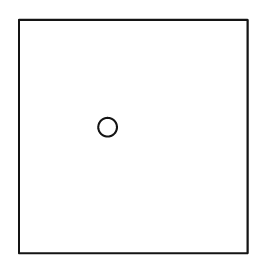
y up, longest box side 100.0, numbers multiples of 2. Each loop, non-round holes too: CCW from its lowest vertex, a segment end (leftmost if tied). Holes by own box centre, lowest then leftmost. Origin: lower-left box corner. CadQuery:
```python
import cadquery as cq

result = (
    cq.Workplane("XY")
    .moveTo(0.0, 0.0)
    .lineTo(98.0, 0.0)
    .lineTo(98.0, 100.0)
    .lineTo(0.0, 100.0)
    .close()
    .moveTo(38.0, 54.0)
    .circle(4.0)
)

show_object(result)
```